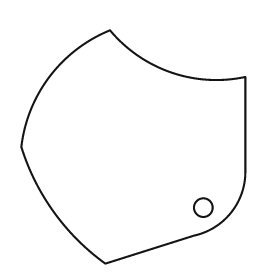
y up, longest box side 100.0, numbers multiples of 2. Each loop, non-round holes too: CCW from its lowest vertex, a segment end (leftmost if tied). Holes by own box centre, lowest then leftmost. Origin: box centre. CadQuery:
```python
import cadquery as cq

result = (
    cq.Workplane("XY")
    .moveTo(-12.0, -50.0)
    .lineTo(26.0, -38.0)
    .threePointArc((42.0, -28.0), (48.0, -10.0))
    .lineTo(48.0, 30.0)
    .threePointArc((16.0, 32.0), (-10.0, 50.0))
    .threePointArc((-36.0, 30.0), (-48.0, 0.0))
    .threePointArc((-34.0, -28.0), (-12.0, -50.0))
    .close()
    .moveTo(30.0, -26.0)
    .circle(4.0)
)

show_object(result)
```